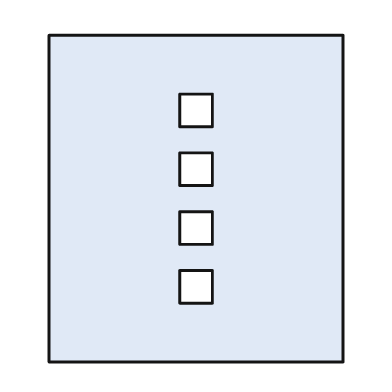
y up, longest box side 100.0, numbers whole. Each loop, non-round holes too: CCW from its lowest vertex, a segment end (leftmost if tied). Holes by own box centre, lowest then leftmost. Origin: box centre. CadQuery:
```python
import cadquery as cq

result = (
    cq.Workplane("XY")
    .moveTo(-45.0, -50.0)
    .lineTo(45.0, -50.0)
    .lineTo(45.0, 50.0)
    .lineTo(-45.0, 50.0)
    .close()
    .moveTo(-5.0, -32.0)
    .lineTo(5.0, -32.0)
    .lineTo(5.0, -22.0)
    .lineTo(-5.0, -22.0)
    .close()
    .moveTo(-5.0, -14.0)
    .lineTo(5.0, -14.0)
    .lineTo(5.0, -4.0)
    .lineTo(-5.0, -4.0)
    .close()
    .moveTo(-5.0, 4.0)
    .lineTo(5.0, 4.0)
    .lineTo(5.0, 14.0)
    .lineTo(-5.0, 14.0)
    .close()
    .moveTo(-5.0, 22.0)
    .lineTo(5.0, 22.0)
    .lineTo(5.0, 32.0)
    .lineTo(-5.0, 32.0)
    .close()
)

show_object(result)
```